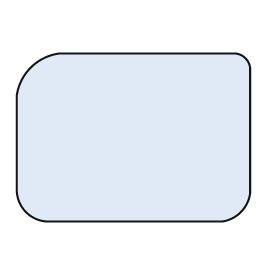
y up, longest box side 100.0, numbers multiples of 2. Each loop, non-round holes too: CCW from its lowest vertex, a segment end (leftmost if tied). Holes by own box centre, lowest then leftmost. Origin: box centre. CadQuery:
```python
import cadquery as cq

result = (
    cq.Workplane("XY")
    .moveTo(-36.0, -36.0)
    .lineTo(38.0, -36.0)
    .threePointArc((46.0, -32.0), (50.0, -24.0))
    .lineTo(50.0, 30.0)
    .threePointArc((48.0, 34.0), (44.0, 36.0))
    .lineTo(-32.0, 36.0)
    .threePointArc((-44.0, 30.0), (-50.0, 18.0))
    .lineTo(-50.0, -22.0)
    .threePointArc((-46.0, -32.0), (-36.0, -36.0))
    .close()
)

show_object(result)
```